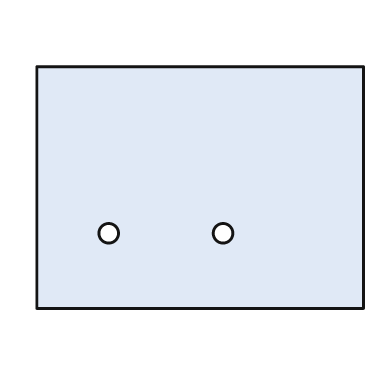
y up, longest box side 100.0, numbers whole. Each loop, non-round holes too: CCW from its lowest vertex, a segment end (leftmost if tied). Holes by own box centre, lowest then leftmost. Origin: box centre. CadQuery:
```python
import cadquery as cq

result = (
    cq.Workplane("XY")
    .moveTo(-50.0, -37.0)
    .lineTo(50.0, -37.0)
    .lineTo(50.0, 37.0)
    .lineTo(-50.0, 37.0)
    .close()
    .moveTo(-28.0, -14.0)
    .circle(3.0)
    .moveTo(7.0, -14.0)
    .circle(3.0)
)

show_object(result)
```